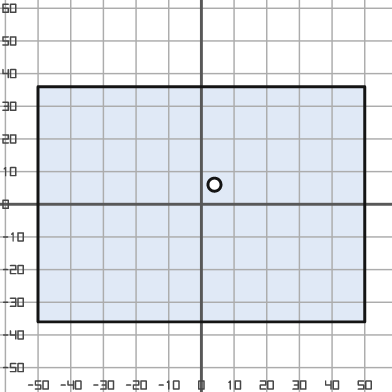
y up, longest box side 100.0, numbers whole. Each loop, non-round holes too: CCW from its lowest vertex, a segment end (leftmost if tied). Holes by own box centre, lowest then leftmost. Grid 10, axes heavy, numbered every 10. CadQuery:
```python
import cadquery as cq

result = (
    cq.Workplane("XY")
    .moveTo(-50.0, -36.0)
    .lineTo(50.0, -36.0)
    .lineTo(50.0, 36.0)
    .lineTo(-50.0, 36.0)
    .close()
    .moveTo(4.0, 6.0)
    .circle(2.0)
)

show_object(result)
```